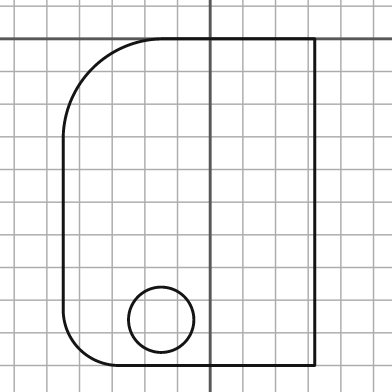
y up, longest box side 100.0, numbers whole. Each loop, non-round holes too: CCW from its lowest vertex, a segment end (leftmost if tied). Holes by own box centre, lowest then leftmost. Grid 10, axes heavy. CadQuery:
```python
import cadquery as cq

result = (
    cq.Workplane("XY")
    .moveTo(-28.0, -100.0)
    .lineTo(32.0, -100.0)
    .lineTo(32.0, 0.0)
    .lineTo(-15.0, 0.0)
    .threePointArc((-36.0, -9.0), (-45.0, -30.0))
    .lineTo(-45.0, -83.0)
    .threePointArc((-40.0, -95.0), (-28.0, -100.0))
    .close()
    .moveTo(-15.0, -86.0)
    .circle(10.0)
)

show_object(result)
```